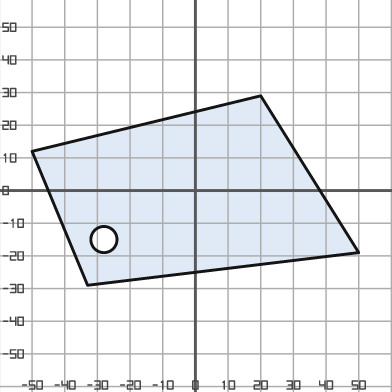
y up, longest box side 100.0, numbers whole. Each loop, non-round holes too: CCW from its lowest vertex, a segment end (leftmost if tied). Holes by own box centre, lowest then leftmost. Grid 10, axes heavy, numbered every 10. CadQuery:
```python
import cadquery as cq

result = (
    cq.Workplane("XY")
    .moveTo(-33.0, -29.0)
    .lineTo(50.0, -19.0)
    .lineTo(20.0, 29.0)
    .lineTo(-50.0, 12.0)
    .close()
    .moveTo(-28.0, -15.0)
    .circle(4.0)
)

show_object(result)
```